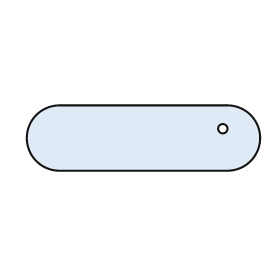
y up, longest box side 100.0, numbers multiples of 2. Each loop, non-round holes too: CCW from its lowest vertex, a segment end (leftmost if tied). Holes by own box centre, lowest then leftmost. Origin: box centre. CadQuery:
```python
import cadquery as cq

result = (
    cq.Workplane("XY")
    .moveTo(-36.0, -14.0)
    .lineTo(36.0, -14.0)
    .threePointArc((50.0, 0.0), (36.0, 14.0))
    .lineTo(-36.0, 14.0)
    .threePointArc((-50.0, 0.0), (-36.0, -14.0))
    .close()
    .moveTo(34.0, 4.0)
    .circle(2.0)
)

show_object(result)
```